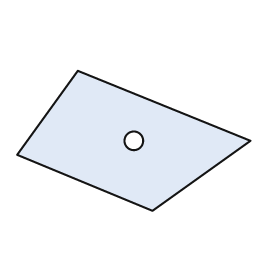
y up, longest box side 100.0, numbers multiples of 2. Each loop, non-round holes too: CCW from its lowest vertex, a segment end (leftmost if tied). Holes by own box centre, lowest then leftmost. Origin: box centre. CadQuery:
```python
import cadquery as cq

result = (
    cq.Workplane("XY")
    .moveTo(8.0, -30.0)
    .lineTo(50.0, 0.0)
    .lineTo(-24.0, 30.0)
    .lineTo(-50.0, -6.0)
    .close()
    .moveTo(0.0, 0.0)
    .circle(4.0)
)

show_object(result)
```